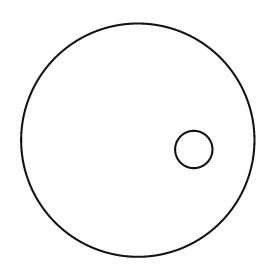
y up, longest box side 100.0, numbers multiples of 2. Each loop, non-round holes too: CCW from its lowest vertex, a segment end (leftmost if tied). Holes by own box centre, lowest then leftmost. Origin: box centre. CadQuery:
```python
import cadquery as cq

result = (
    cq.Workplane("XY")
    .moveTo(0.0, 0.0)
    .circle(50.0)
    .moveTo(24.0, -4.0)
    .circle(8.0)
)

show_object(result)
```